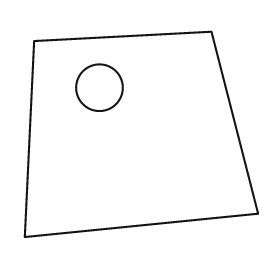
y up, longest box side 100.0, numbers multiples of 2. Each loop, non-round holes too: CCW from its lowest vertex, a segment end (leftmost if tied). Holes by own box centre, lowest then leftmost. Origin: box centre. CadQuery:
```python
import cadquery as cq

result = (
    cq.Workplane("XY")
    .moveTo(-50.0, -44.0)
    .lineTo(50.0, -34.0)
    .lineTo(30.0, 44.0)
    .lineTo(-46.0, 40.0)
    .close()
    .moveTo(-18.0, 20.0)
    .circle(10.0)
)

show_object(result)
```